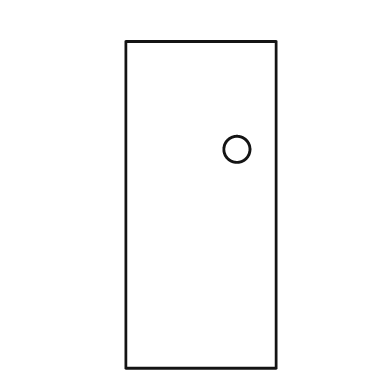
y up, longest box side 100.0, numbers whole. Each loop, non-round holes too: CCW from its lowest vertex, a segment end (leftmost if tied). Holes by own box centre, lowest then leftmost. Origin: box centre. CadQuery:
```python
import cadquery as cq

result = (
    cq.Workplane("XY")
    .moveTo(-23.0, -50.0)
    .lineTo(23.0, -50.0)
    .lineTo(23.0, 50.0)
    .lineTo(-23.0, 50.0)
    .close()
    .moveTo(11.0, 17.0)
    .circle(4.0)
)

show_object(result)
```